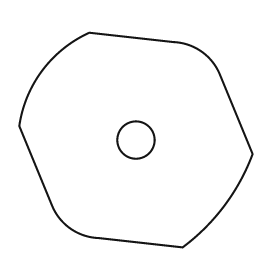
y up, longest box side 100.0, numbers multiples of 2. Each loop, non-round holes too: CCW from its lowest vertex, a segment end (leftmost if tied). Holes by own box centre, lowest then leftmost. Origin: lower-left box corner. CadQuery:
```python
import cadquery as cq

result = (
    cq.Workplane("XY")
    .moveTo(70.0, 0.0)
    .threePointArc((88.0, 18.0), (100.0, 40.0))
    .lineTo(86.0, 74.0)
    .threePointArc((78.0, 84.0), (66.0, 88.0))
    .lineTo(30.0, 92.0)
    .threePointArc((10.0, 76.0), (0.0, 52.0))
    .lineTo(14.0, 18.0)
    .threePointArc((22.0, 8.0), (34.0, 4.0))
    .close()
    .moveTo(50.0, 46.0)
    .circle(8.0)
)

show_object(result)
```